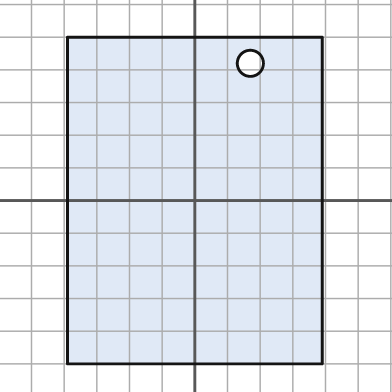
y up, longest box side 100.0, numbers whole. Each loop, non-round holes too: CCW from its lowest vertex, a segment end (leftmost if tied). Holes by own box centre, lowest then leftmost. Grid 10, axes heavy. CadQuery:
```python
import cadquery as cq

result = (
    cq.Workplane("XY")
    .moveTo(-39.0, -50.0)
    .lineTo(39.0, -50.0)
    .lineTo(39.0, 50.0)
    .lineTo(-39.0, 50.0)
    .close()
    .moveTo(17.0, 42.0)
    .circle(4.0)
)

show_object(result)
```